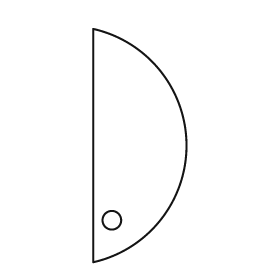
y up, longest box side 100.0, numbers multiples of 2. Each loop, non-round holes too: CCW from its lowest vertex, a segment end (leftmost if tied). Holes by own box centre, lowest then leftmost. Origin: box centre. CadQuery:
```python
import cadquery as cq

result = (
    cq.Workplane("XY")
    .moveTo(-20.0, -50.0)
    .threePointArc((20.0, 0.0), (-20.0, 50.0))
    .close()
    .moveTo(-12.0, -32.0)
    .circle(4.0)
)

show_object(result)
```